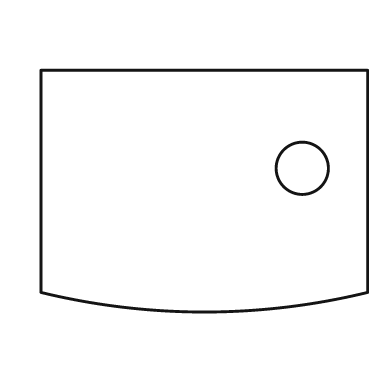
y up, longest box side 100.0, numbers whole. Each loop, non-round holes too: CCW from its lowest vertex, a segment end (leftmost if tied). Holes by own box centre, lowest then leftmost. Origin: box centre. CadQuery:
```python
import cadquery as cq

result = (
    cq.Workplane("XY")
    .moveTo(-50.0, -31.0)
    .threePointArc((0.0, -37.0), (50.0, -31.0))
    .lineTo(50.0, 37.0)
    .lineTo(-50.0, 37.0)
    .close()
    .moveTo(30.0, 7.0)
    .circle(8.0)
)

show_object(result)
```